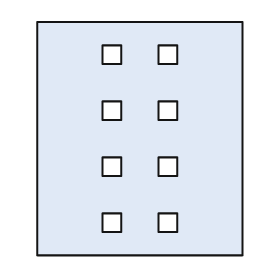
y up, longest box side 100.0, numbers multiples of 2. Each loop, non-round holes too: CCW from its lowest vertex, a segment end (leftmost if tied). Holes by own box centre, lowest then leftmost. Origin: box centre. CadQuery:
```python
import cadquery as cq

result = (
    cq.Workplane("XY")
    .moveTo(-44.0, -50.0)
    .lineTo(44.0, -50.0)
    .lineTo(44.0, 50.0)
    .lineTo(-44.0, 50.0)
    .close()
    .moveTo(-16.0, -40.0)
    .lineTo(-8.0, -40.0)
    .lineTo(-8.0, -32.0)
    .lineTo(-16.0, -32.0)
    .close()
    .moveTo(8.0, -40.0)
    .lineTo(16.0, -40.0)
    .lineTo(16.0, -32.0)
    .lineTo(8.0, -32.0)
    .close()
    .moveTo(-16.0, -16.0)
    .lineTo(-8.0, -16.0)
    .lineTo(-8.0, -8.0)
    .lineTo(-16.0, -8.0)
    .close()
    .moveTo(8.0, -16.0)
    .lineTo(16.0, -16.0)
    .lineTo(16.0, -8.0)
    .lineTo(8.0, -8.0)
    .close()
    .moveTo(-16.0, 8.0)
    .lineTo(-8.0, 8.0)
    .lineTo(-8.0, 16.0)
    .lineTo(-16.0, 16.0)
    .close()
    .moveTo(8.0, 8.0)
    .lineTo(16.0, 8.0)
    .lineTo(16.0, 16.0)
    .lineTo(8.0, 16.0)
    .close()
    .moveTo(-16.0, 32.0)
    .lineTo(-8.0, 32.0)
    .lineTo(-8.0, 40.0)
    .lineTo(-16.0, 40.0)
    .close()
    .moveTo(8.0, 32.0)
    .lineTo(16.0, 32.0)
    .lineTo(16.0, 40.0)
    .lineTo(8.0, 40.0)
    .close()
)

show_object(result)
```